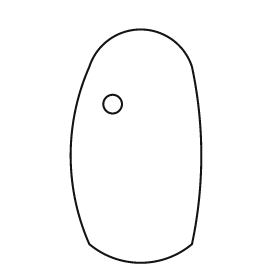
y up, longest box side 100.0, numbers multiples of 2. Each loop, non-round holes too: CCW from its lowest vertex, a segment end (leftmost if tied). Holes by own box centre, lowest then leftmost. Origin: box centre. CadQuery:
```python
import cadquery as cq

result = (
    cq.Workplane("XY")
    .moveTo(-20.0, -42.0)
    .threePointArc((2.0, -50.0), (24.0, -42.0))
    .threePointArc((28.0, -4.0), (24.0, 34.0))
    .threePointArc((2.0, 50.0), (-20.0, 34.0))
    .threePointArc((-28.0, -4.0), (-20.0, -42.0))
    .close()
    .moveTo(-10.0, 18.0)
    .circle(4.0)
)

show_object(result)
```